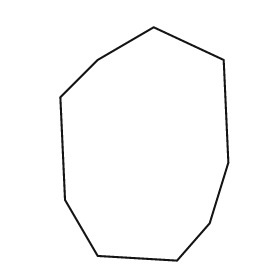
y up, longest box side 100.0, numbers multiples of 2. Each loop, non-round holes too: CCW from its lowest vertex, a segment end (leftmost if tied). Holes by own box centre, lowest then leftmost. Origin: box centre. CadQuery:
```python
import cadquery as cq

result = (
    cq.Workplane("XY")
    .moveTo(14.0, -50.0)
    .lineTo(28.0, -34.0)
    .lineTo(36.0, -8.0)
    .lineTo(34.0, 36.0)
    .lineTo(4.0, 50.0)
    .lineTo(-20.0, 36.0)
    .lineTo(-36.0, 20.0)
    .lineTo(-34.0, -24.0)
    .lineTo(-20.0, -48.0)
    .close()
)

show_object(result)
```